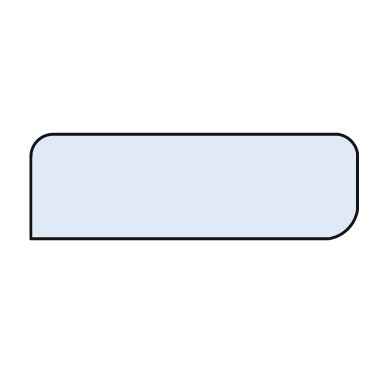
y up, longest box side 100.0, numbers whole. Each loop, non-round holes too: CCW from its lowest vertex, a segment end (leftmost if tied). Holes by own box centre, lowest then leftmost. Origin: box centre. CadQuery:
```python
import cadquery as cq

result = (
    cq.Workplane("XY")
    .moveTo(-50.0, -16.0)
    .lineTo(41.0, -16.0)
    .threePointArc((47.0, -13.0), (50.0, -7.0))
    .lineTo(50.0, 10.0)
    .threePointArc((48.0, 14.0), (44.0, 16.0))
    .lineTo(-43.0, 16.0)
    .threePointArc((-48.0, 14.0), (-50.0, 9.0))
    .close()
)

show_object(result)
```